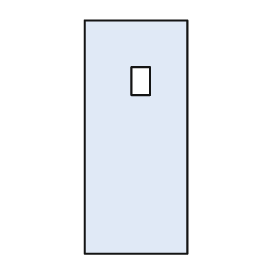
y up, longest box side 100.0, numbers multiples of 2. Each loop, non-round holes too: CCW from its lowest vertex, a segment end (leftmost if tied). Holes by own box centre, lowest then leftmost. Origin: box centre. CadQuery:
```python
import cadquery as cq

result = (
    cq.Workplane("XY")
    .moveTo(-22.0, -50.0)
    .lineTo(22.0, -50.0)
    .lineTo(22.0, 50.0)
    .lineTo(-22.0, 50.0)
    .close()
    .moveTo(-2.0, 18.0)
    .lineTo(6.0, 18.0)
    .lineTo(6.0, 30.0)
    .lineTo(-2.0, 30.0)
    .close()
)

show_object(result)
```